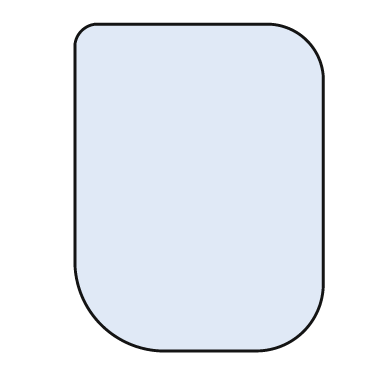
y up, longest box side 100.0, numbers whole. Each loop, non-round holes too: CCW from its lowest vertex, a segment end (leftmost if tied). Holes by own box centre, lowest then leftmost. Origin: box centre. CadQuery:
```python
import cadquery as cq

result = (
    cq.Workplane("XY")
    .moveTo(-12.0, -50.0)
    .lineTo(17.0, -50.0)
    .threePointArc((32.0, -44.0), (38.0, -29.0))
    .lineTo(38.0, 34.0)
    .threePointArc((33.0, 45.0), (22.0, 50.0))
    .lineTo(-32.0, 50.0)
    .threePointArc((-36.0, 48.0), (-38.0, 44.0))
    .lineTo(-38.0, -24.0)
    .threePointArc((-30.0, -42.0), (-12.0, -50.0))
    .close()
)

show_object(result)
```